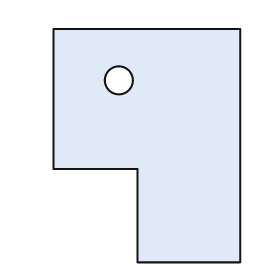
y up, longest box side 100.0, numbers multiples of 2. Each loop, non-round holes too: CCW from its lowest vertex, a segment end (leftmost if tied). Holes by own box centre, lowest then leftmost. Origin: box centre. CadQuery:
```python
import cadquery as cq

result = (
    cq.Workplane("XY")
    .moveTo(-4.0, -50.0)
    .lineTo(40.0, -50.0)
    .lineTo(40.0, 50.0)
    .lineTo(-40.0, 50.0)
    .lineTo(-40.0, -10.0)
    .lineTo(-4.0, -10.0)
    .close()
    .moveTo(-12.0, 28.0)
    .circle(6.0)
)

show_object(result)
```